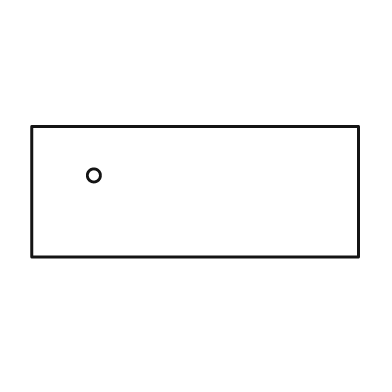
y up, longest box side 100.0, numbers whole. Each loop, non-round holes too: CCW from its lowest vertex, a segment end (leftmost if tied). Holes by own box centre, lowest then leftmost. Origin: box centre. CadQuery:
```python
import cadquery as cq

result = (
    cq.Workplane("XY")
    .moveTo(-50.0, -20.0)
    .lineTo(50.0, -20.0)
    .lineTo(50.0, 20.0)
    .lineTo(-50.0, 20.0)
    .close()
    .moveTo(-31.0, 5.0)
    .circle(2.0)
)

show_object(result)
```